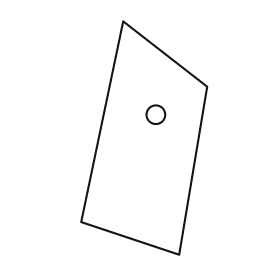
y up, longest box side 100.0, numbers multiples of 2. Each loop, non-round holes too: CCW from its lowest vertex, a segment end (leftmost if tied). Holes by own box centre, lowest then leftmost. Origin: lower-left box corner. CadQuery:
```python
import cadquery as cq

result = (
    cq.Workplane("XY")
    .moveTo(42.0, 0.0)
    .lineTo(54.0, 72.0)
    .lineTo(18.0, 100.0)
    .lineTo(0.0, 14.0)
    .close()
    .moveTo(32.0, 60.0)
    .circle(4.0)
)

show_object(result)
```